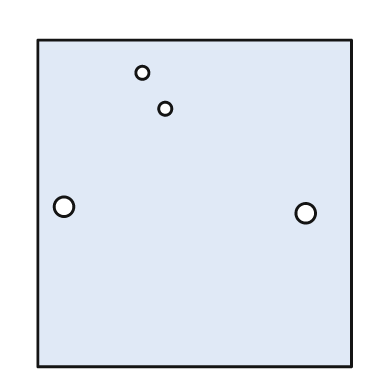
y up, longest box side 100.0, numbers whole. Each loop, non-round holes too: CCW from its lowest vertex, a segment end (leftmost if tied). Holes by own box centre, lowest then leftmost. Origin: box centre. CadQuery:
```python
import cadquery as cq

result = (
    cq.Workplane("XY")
    .moveTo(-48.0, -50.0)
    .lineTo(48.0, -50.0)
    .lineTo(48.0, 50.0)
    .lineTo(-48.0, 50.0)
    .close()
    .moveTo(34.0, -3.0)
    .circle(3.0)
    .moveTo(-40.0, -1.0)
    .circle(3.0)
    .moveTo(-9.0, 29.0)
    .circle(2.0)
    .moveTo(-16.0, 40.0)
    .circle(2.0)
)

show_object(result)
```